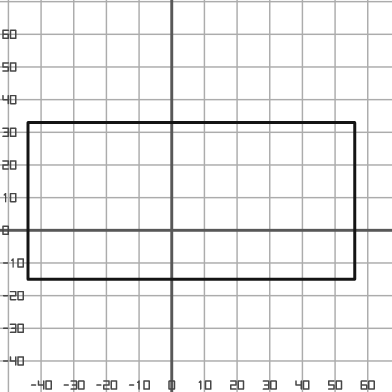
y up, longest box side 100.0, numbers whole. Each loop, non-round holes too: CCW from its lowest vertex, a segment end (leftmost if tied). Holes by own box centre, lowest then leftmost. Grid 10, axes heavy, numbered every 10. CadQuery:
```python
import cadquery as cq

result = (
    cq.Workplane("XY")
    .moveTo(-44.0, -15.0)
    .lineTo(56.0, -15.0)
    .lineTo(56.0, 33.0)
    .lineTo(-44.0, 33.0)
    .close()
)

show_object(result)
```